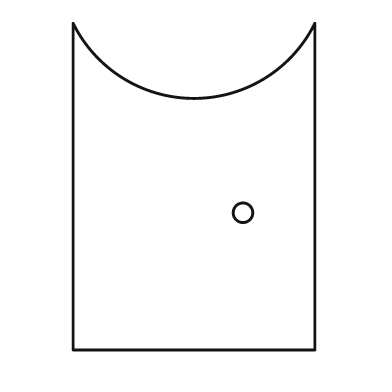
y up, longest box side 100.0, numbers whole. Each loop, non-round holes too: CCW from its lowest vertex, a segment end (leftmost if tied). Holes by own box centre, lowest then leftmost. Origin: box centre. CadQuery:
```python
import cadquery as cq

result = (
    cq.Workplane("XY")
    .moveTo(-37.0, -50.0)
    .lineTo(37.0, -50.0)
    .lineTo(37.0, 50.0)
    .threePointArc((0.0, 27.0), (-37.0, 50.0))
    .close()
    .moveTo(15.0, -8.0)
    .circle(3.0)
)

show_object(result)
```